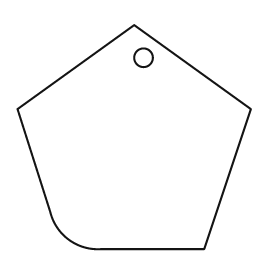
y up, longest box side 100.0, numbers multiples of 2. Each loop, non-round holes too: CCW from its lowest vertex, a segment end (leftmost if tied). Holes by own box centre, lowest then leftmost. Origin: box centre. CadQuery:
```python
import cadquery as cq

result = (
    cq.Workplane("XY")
    .moveTo(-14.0, -48.0)
    .lineTo(30.0, -48.0)
    .lineTo(50.0, 12.0)
    .lineTo(0.0, 48.0)
    .lineTo(-50.0, 12.0)
    .lineTo(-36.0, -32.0)
    .threePointArc((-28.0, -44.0), (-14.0, -48.0))
    .close()
    .moveTo(4.0, 34.0)
    .circle(4.0)
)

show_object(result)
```